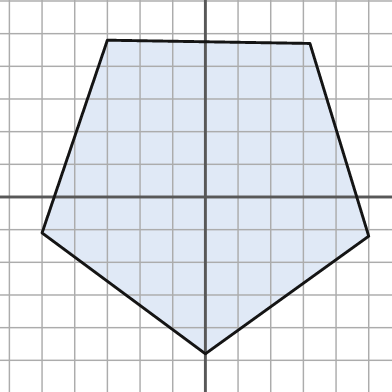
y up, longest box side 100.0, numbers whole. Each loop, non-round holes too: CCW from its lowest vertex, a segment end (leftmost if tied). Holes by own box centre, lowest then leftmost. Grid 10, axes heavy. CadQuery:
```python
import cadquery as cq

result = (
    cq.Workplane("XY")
    .moveTo(0.0, -48.0)
    .lineTo(50.0, -12.0)
    .lineTo(32.0, 47.0)
    .lineTo(-30.0, 48.0)
    .lineTo(-50.0, -11.0)
    .close()
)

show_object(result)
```